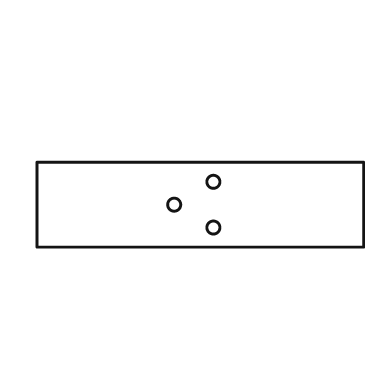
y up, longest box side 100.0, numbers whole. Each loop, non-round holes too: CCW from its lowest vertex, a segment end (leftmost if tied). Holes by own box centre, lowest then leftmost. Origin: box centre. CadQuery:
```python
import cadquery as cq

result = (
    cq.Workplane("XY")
    .moveTo(-50.0, -13.0)
    .lineTo(50.0, -13.0)
    .lineTo(50.0, 13.0)
    .lineTo(-50.0, 13.0)
    .close()
    .moveTo(4.0, -7.0)
    .circle(2.0)
    .moveTo(-8.0, 0.0)
    .circle(2.0)
    .moveTo(4.0, 7.0)
    .circle(2.0)
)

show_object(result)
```